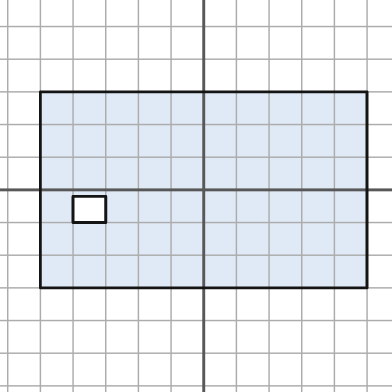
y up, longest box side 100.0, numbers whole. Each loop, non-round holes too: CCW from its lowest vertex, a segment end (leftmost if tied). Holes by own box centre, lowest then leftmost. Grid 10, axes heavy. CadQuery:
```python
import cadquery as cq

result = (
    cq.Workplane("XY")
    .moveTo(-50.0, -30.0)
    .lineTo(50.0, -30.0)
    .lineTo(50.0, 30.0)
    .lineTo(-50.0, 30.0)
    .close()
    .moveTo(-40.0, -10.0)
    .lineTo(-30.0, -10.0)
    .lineTo(-30.0, -2.0)
    .lineTo(-40.0, -2.0)
    .close()
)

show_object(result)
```